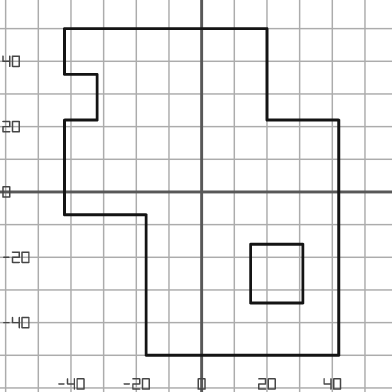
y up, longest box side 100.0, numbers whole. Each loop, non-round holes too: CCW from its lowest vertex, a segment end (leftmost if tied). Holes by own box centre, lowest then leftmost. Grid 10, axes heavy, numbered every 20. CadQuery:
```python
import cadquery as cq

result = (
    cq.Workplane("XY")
    .moveTo(-17.0, -50.0)
    .lineTo(42.0, -50.0)
    .lineTo(42.0, 22.0)
    .lineTo(20.0, 22.0)
    .lineTo(20.0, 50.0)
    .lineTo(-42.0, 50.0)
    .lineTo(-42.0, 36.0)
    .lineTo(-32.0, 36.0)
    .lineTo(-32.0, 22.0)
    .lineTo(-42.0, 22.0)
    .lineTo(-42.0, -7.0)
    .lineTo(-17.0, -7.0)
    .close()
    .moveTo(15.0, -34.0)
    .lineTo(31.0, -34.0)
    .lineTo(31.0, -16.0)
    .lineTo(15.0, -16.0)
    .close()
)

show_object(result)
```